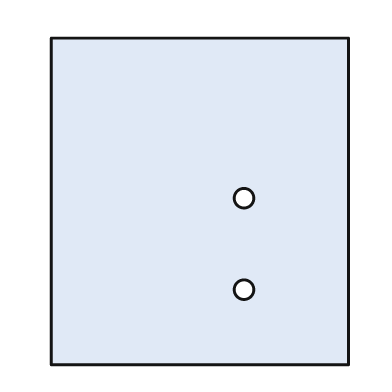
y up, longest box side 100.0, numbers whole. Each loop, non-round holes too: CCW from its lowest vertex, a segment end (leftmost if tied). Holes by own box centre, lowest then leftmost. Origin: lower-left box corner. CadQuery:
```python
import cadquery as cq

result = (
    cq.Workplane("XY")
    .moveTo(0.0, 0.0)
    .lineTo(91.0, 0.0)
    .lineTo(91.0, 100.0)
    .lineTo(0.0, 100.0)
    .close()
    .moveTo(59.0, 23.0)
    .circle(3.0)
    .moveTo(59.0, 51.0)
    .circle(3.0)
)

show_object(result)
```